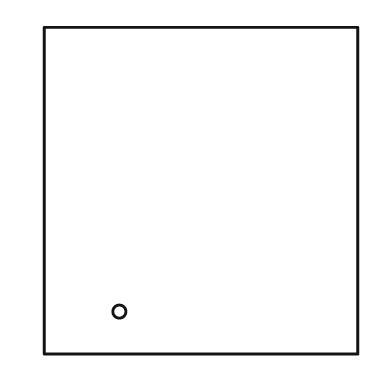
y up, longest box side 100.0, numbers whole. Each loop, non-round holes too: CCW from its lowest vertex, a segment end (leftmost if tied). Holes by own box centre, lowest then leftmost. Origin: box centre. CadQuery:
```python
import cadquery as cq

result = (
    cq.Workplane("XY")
    .moveTo(-48.0, -50.0)
    .lineTo(48.0, -50.0)
    .lineTo(48.0, 50.0)
    .lineTo(-48.0, 50.0)
    .close()
    .moveTo(-25.0, -37.0)
    .circle(2.0)
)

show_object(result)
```